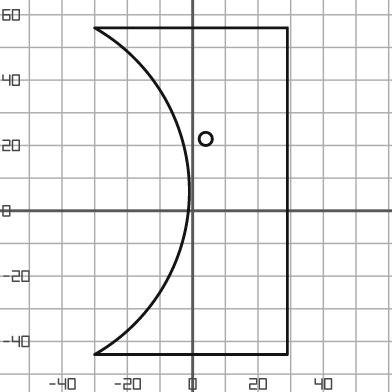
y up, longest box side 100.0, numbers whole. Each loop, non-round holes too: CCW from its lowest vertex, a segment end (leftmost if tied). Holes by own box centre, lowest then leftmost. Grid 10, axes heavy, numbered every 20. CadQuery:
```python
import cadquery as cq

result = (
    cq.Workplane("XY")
    .moveTo(-30.0, -44.0)
    .lineTo(29.0, -44.0)
    .lineTo(29.0, 56.0)
    .lineTo(-30.0, 56.0)
    .threePointArc((-1.0, 6.0), (-30.0, -44.0))
    .close()
    .moveTo(4.0, 22.0)
    .circle(2.0)
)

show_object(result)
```